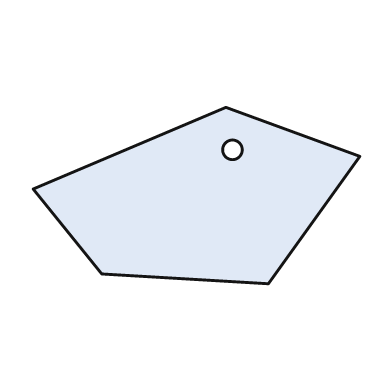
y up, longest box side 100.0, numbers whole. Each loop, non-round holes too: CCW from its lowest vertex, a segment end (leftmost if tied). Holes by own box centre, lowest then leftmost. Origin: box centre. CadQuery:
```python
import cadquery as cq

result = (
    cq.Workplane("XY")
    .moveTo(22.0, -27.0)
    .lineTo(50.0, 12.0)
    .lineTo(9.0, 27.0)
    .lineTo(-50.0, 2.0)
    .lineTo(-29.0, -24.0)
    .close()
    .moveTo(11.0, 14.0)
    .circle(3.0)
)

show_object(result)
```